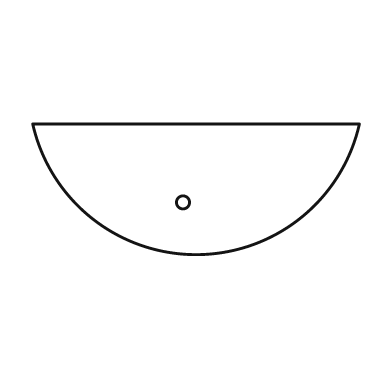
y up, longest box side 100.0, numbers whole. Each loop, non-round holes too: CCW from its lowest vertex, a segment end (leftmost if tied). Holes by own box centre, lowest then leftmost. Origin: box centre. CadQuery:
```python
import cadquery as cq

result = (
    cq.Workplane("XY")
    .moveTo(-50.0, 20.0)
    .threePointArc((0.0, -20.0), (50.0, 20.0))
    .close()
    .moveTo(-4.0, -4.0)
    .circle(2.0)
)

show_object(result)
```